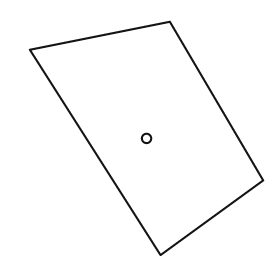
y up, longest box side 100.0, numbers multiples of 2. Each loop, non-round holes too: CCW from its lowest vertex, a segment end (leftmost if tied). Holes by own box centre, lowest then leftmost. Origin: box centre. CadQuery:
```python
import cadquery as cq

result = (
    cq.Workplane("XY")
    .moveTo(6.0, -50.0)
    .lineTo(50.0, -18.0)
    .lineTo(10.0, 50.0)
    .lineTo(-50.0, 38.0)
    .close()
    .moveTo(0.0, 0.0)
    .circle(2.0)
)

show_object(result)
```